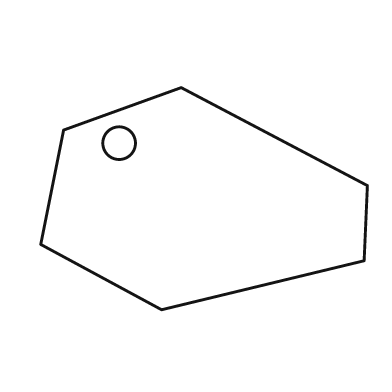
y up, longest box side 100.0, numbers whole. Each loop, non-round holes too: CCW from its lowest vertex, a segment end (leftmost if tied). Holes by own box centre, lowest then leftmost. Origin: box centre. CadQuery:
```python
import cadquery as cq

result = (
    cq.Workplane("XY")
    .moveTo(-13.0, -34.0)
    .lineTo(49.0, -19.0)
    .lineTo(50.0, 4.0)
    .lineTo(-7.0, 34.0)
    .lineTo(-43.0, 21.0)
    .lineTo(-50.0, -14.0)
    .close()
    .moveTo(-26.0, 17.0)
    .circle(5.0)
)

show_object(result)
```